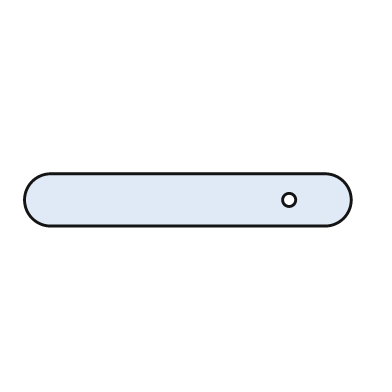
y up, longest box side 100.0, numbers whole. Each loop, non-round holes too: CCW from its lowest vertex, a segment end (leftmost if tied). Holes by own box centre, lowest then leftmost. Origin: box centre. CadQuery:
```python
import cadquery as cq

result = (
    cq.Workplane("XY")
    .moveTo(-42.0, -8.0)
    .lineTo(42.0, -8.0)
    .threePointArc((50.0, 0.0), (42.0, 8.0))
    .lineTo(-42.0, 8.0)
    .threePointArc((-50.0, 0.0), (-42.0, -8.0))
    .close()
    .moveTo(31.0, 0.0)
    .circle(2.0)
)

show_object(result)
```